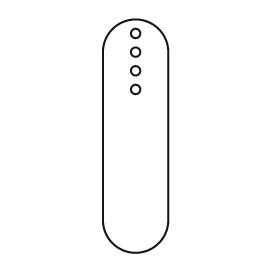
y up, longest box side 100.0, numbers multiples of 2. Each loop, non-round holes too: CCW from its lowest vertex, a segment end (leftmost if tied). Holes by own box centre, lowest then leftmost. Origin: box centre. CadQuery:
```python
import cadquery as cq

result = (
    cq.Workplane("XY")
    .moveTo(-14.0, -36.0)
    .threePointArc((0.0, -50.0), (14.0, -36.0))
    .lineTo(14.0, 36.0)
    .threePointArc((0.0, 50.0), (-14.0, 36.0))
    .close()
    .moveTo(0.0, 20.0)
    .circle(2.0)
    .moveTo(0.0, 28.0)
    .circle(2.0)
    .moveTo(0.0, 36.0)
    .circle(2.0)
    .moveTo(0.0, 44.0)
    .circle(2.0)
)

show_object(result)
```